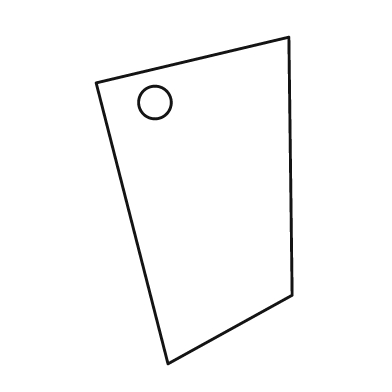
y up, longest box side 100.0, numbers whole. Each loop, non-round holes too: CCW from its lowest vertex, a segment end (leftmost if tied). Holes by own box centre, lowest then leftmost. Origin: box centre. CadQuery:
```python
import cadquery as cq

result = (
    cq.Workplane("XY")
    .moveTo(-8.0, -50.0)
    .lineTo(30.0, -29.0)
    .lineTo(29.0, 50.0)
    .lineTo(-30.0, 36.0)
    .close()
    .moveTo(-12.0, 30.0)
    .circle(5.0)
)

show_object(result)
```